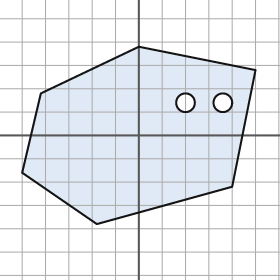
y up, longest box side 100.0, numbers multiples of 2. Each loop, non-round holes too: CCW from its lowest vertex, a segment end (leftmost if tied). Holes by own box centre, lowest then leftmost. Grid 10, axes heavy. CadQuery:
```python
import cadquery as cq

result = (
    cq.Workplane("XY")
    .moveTo(-18.0, -38.0)
    .lineTo(40.0, -22.0)
    .lineTo(50.0, 28.0)
    .lineTo(0.0, 38.0)
    .lineTo(-42.0, 18.0)
    .lineTo(-50.0, -16.0)
    .close()
    .moveTo(20.0, 14.0)
    .circle(4.0)
    .moveTo(36.0, 14.0)
    .circle(4.0)
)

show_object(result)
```